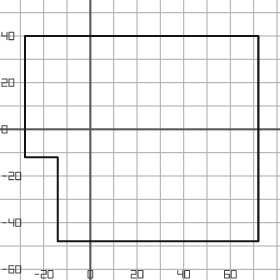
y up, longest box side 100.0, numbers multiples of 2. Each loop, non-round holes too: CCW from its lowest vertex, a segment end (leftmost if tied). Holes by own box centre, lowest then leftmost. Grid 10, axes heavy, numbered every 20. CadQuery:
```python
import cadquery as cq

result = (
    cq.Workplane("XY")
    .moveTo(-14.0, -48.0)
    .lineTo(72.0, -48.0)
    .lineTo(72.0, 40.0)
    .lineTo(-28.0, 40.0)
    .lineTo(-28.0, -12.0)
    .lineTo(-14.0, -12.0)
    .close()
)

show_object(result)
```